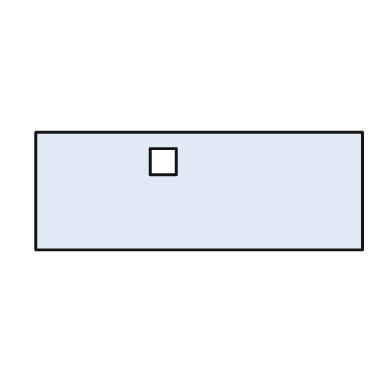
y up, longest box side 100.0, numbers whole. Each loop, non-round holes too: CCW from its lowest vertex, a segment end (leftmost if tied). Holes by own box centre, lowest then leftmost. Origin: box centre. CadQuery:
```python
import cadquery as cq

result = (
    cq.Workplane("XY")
    .moveTo(-50.0, -18.0)
    .lineTo(50.0, -18.0)
    .lineTo(50.0, 18.0)
    .lineTo(-50.0, 18.0)
    .close()
    .moveTo(-15.0, 5.0)
    .lineTo(-7.0, 5.0)
    .lineTo(-7.0, 13.0)
    .lineTo(-15.0, 13.0)
    .close()
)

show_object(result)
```